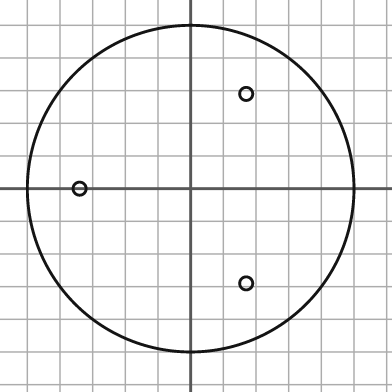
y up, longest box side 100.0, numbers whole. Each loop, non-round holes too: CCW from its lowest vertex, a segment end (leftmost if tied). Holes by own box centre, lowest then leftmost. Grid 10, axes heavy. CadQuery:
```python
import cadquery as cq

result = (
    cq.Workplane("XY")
    .moveTo(0.0, 0.0)
    .circle(50.0)
    .moveTo(17.0, -29.0)
    .circle(2.0)
    .moveTo(-34.0, 0.0)
    .circle(2.0)
    .moveTo(17.0, 29.0)
    .circle(2.0)
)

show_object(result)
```